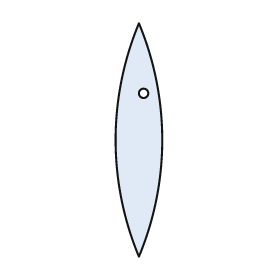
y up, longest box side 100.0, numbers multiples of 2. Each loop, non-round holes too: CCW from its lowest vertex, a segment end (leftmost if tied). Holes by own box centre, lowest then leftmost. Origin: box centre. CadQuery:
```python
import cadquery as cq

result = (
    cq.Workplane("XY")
    .moveTo(0.0, -50.0)
    .threePointArc((10.0, 0.0), (0.0, 50.0))
    .threePointArc((-10.0, 0.0), (0.0, -50.0))
    .close()
    .moveTo(2.0, 20.0)
    .circle(2.0)
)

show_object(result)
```